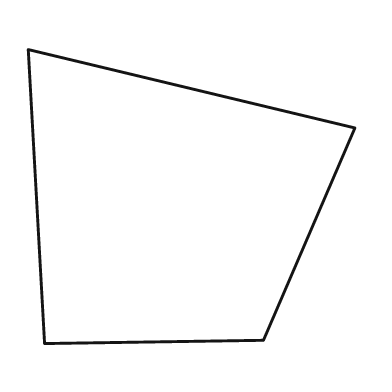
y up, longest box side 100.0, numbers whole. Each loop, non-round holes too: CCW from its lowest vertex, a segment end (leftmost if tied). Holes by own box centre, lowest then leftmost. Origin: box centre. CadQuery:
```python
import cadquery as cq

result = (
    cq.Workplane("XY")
    .moveTo(-45.0, -45.0)
    .lineTo(22.0, -44.0)
    .lineTo(50.0, 21.0)
    .lineTo(-50.0, 45.0)
    .close()
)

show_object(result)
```